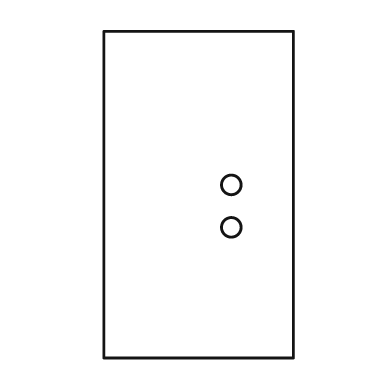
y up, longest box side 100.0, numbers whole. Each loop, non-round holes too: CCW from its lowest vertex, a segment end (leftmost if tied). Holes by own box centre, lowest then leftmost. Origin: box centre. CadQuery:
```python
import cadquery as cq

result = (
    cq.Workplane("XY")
    .moveTo(-29.0, -50.0)
    .lineTo(29.0, -50.0)
    .lineTo(29.0, 50.0)
    .lineTo(-29.0, 50.0)
    .close()
    .moveTo(10.0, -10.0)
    .circle(3.0)
    .moveTo(10.0, 3.0)
    .circle(3.0)
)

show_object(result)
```